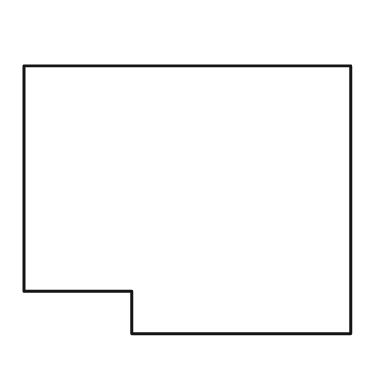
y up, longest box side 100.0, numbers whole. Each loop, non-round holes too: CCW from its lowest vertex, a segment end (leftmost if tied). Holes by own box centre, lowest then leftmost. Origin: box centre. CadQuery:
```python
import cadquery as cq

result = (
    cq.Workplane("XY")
    .moveTo(-17.0, -41.0)
    .lineTo(50.0, -41.0)
    .lineTo(50.0, 41.0)
    .lineTo(-50.0, 41.0)
    .lineTo(-50.0, -28.0)
    .lineTo(-17.0, -28.0)
    .close()
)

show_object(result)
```